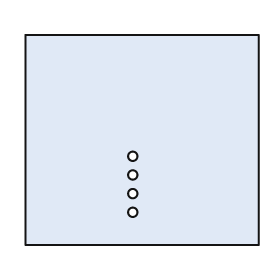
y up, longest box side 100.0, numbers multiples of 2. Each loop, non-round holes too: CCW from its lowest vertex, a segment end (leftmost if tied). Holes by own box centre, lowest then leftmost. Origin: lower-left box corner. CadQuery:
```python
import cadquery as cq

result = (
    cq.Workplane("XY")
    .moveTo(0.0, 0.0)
    .lineTo(100.0, 0.0)
    .lineTo(100.0, 90.0)
    .lineTo(0.0, 90.0)
    .close()
    .moveTo(46.0, 14.0)
    .circle(2.0)
    .moveTo(46.0, 22.0)
    .circle(2.0)
    .moveTo(46.0, 30.0)
    .circle(2.0)
    .moveTo(46.0, 38.0)
    .circle(2.0)
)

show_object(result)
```